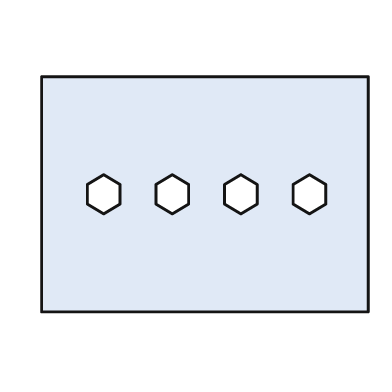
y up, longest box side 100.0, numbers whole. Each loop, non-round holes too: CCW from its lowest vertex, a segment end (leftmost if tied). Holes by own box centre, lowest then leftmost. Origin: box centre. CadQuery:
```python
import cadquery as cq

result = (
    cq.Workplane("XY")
    .moveTo(-50.0, -36.0)
    .lineTo(50.0, -36.0)
    .lineTo(50.0, 36.0)
    .lineTo(-50.0, 36.0)
    .close()
    .moveTo(-31.0, -6.0)
    .lineTo(-26.0, -3.0)
    .lineTo(-26.0, 3.0)
    .lineTo(-31.0, 6.0)
    .lineTo(-36.0, 3.0)
    .lineTo(-36.0, -3.0)
    .close()
    .moveTo(-10.0, -6.0)
    .lineTo(-5.0, -3.0)
    .lineTo(-5.0, 3.0)
    .lineTo(-10.0, 6.0)
    .lineTo(-15.0, 3.0)
    .lineTo(-15.0, -3.0)
    .close()
    .moveTo(11.0, -6.0)
    .lineTo(16.0, -3.0)
    .lineTo(16.0, 3.0)
    .lineTo(11.0, 6.0)
    .lineTo(6.0, 3.0)
    .lineTo(6.0, -3.0)
    .close()
    .moveTo(32.0, -6.0)
    .lineTo(37.0, -3.0)
    .lineTo(37.0, 3.0)
    .lineTo(32.0, 6.0)
    .lineTo(27.0, 3.0)
    .lineTo(27.0, -3.0)
    .close()
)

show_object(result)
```